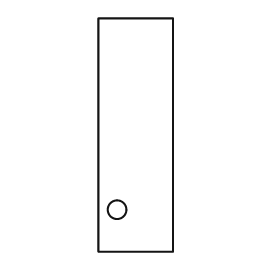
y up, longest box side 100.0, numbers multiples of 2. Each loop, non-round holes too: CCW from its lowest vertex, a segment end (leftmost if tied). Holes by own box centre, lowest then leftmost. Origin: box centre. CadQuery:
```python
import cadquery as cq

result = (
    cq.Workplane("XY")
    .moveTo(-16.0, -50.0)
    .lineTo(16.0, -50.0)
    .lineTo(16.0, 50.0)
    .lineTo(-16.0, 50.0)
    .close()
    .moveTo(-8.0, -32.0)
    .circle(4.0)
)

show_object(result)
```